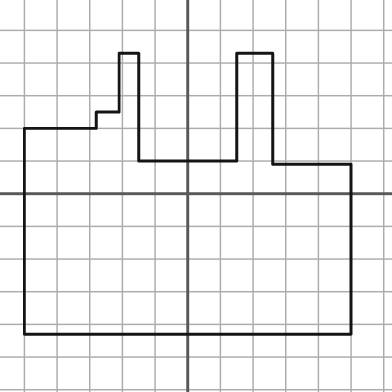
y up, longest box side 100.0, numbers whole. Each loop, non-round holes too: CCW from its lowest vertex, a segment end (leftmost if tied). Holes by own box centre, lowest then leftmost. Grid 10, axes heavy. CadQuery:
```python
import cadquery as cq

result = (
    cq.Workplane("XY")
    .moveTo(-50.0, -43.0)
    .lineTo(50.0, -43.0)
    .lineTo(50.0, 9.0)
    .lineTo(26.0, 9.0)
    .lineTo(26.0, 43.0)
    .lineTo(15.0, 43.0)
    .lineTo(15.0, 10.0)
    .lineTo(-15.0, 10.0)
    .lineTo(-15.0, 43.0)
    .lineTo(-21.0, 43.0)
    .lineTo(-21.0, 25.0)
    .lineTo(-28.0, 25.0)
    .lineTo(-28.0, 20.0)
    .lineTo(-50.0, 20.0)
    .close()
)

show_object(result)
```